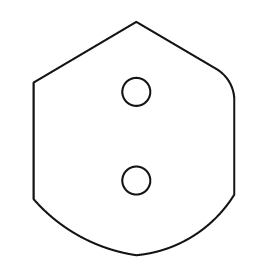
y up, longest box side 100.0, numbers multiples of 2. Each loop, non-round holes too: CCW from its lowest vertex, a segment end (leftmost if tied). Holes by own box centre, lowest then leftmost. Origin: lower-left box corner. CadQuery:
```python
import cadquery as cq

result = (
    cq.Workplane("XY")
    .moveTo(44.0, 0.0)
    .threePointArc((68.0, 8.0), (86.0, 26.0))
    .lineTo(86.0, 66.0)
    .threePointArc((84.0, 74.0), (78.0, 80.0))
    .lineTo(44.0, 100.0)
    .lineTo(0.0, 74.0)
    .lineTo(0.0, 24.0)
    .threePointArc((20.0, 8.0), (44.0, 0.0))
    .close()
    .moveTo(44.0, 32.0)
    .circle(6.0)
    .moveTo(44.0, 70.0)
    .circle(6.0)
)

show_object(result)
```